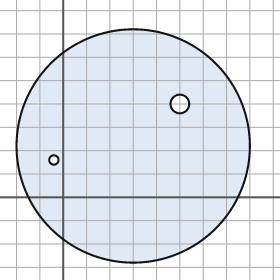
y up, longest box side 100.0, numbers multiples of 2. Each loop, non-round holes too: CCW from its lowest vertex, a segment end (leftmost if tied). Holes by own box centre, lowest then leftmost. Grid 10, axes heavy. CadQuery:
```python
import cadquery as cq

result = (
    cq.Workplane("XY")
    .moveTo(30.0, 22.0)
    .circle(50.0)
    .moveTo(-4.0, 16.0)
    .circle(2.0)
    .moveTo(50.0, 40.0)
    .circle(4.0)
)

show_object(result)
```